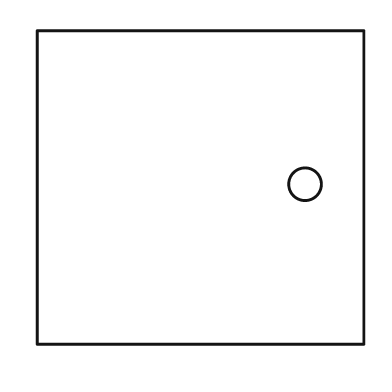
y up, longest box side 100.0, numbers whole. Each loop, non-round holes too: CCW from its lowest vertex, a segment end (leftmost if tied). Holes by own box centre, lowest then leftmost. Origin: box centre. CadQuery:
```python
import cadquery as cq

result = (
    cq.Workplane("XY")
    .moveTo(-50.0, -48.0)
    .lineTo(50.0, -48.0)
    .lineTo(50.0, 48.0)
    .lineTo(-50.0, 48.0)
    .close()
    .moveTo(32.0, 1.0)
    .circle(5.0)
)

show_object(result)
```